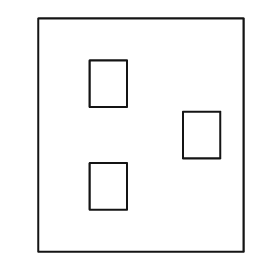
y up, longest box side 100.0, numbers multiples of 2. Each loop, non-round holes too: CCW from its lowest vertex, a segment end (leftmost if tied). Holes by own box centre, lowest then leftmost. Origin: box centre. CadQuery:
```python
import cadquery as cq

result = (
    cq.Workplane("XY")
    .moveTo(-44.0, -50.0)
    .lineTo(44.0, -50.0)
    .lineTo(44.0, 50.0)
    .lineTo(-44.0, 50.0)
    .close()
    .moveTo(-22.0, -32.0)
    .lineTo(-6.0, -32.0)
    .lineTo(-6.0, -12.0)
    .lineTo(-22.0, -12.0)
    .close()
    .moveTo(18.0, -10.0)
    .lineTo(34.0, -10.0)
    .lineTo(34.0, 10.0)
    .lineTo(18.0, 10.0)
    .close()
    .moveTo(-22.0, 12.0)
    .lineTo(-6.0, 12.0)
    .lineTo(-6.0, 32.0)
    .lineTo(-22.0, 32.0)
    .close()
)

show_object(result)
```